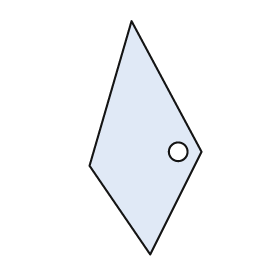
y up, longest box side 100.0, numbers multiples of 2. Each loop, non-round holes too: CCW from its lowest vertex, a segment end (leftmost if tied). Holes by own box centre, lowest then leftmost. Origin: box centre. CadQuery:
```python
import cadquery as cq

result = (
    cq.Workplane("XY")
    .moveTo(2.0, -50.0)
    .lineTo(24.0, -6.0)
    .lineTo(-6.0, 50.0)
    .lineTo(-24.0, -12.0)
    .close()
    .moveTo(14.0, -6.0)
    .circle(4.0)
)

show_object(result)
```